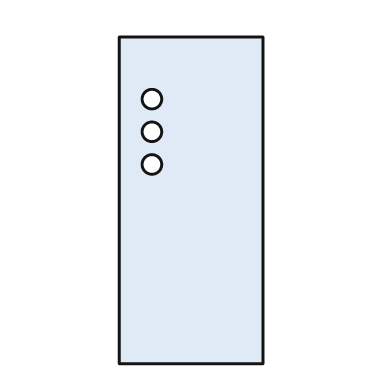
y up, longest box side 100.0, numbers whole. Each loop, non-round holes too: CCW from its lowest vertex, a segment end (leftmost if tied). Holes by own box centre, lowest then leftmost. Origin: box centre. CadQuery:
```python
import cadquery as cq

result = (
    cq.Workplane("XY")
    .moveTo(-22.0, -50.0)
    .lineTo(22.0, -50.0)
    .lineTo(22.0, 50.0)
    .lineTo(-22.0, 50.0)
    .close()
    .moveTo(-12.0, 11.0)
    .circle(3.0)
    .moveTo(-12.0, 21.0)
    .circle(3.0)
    .moveTo(-12.0, 31.0)
    .circle(3.0)
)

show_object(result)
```